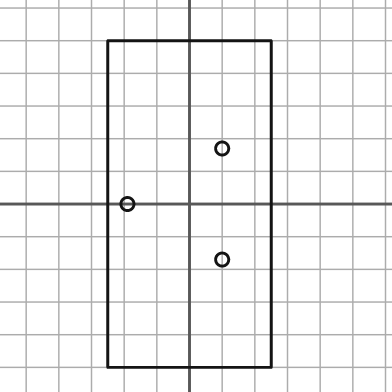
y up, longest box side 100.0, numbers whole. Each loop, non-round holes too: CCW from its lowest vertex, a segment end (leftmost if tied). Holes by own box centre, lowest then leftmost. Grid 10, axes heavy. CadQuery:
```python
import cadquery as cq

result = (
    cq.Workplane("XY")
    .moveTo(-25.0, -50.0)
    .lineTo(25.0, -50.0)
    .lineTo(25.0, 50.0)
    .lineTo(-25.0, 50.0)
    .close()
    .moveTo(10.0, -17.0)
    .circle(2.0)
    .moveTo(-19.0, 0.0)
    .circle(2.0)
    .moveTo(10.0, 17.0)
    .circle(2.0)
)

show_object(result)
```